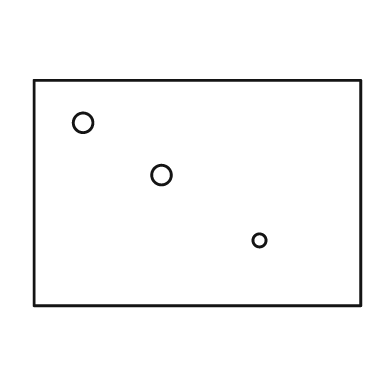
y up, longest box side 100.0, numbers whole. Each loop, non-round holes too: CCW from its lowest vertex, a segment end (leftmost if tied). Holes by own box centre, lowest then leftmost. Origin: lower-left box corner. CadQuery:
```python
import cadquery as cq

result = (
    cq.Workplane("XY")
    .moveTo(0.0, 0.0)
    .lineTo(100.0, 0.0)
    .lineTo(100.0, 69.0)
    .lineTo(0.0, 69.0)
    .close()
    .moveTo(69.0, 20.0)
    .circle(2.0)
    .moveTo(39.0, 40.0)
    .circle(3.0)
    .moveTo(15.0, 56.0)
    .circle(3.0)
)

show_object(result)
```